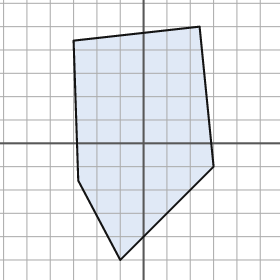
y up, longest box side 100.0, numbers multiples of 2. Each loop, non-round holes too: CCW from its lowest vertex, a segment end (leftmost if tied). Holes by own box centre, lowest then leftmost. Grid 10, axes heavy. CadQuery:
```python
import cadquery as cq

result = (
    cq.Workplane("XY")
    .moveTo(-10.0, -50.0)
    .lineTo(30.0, -10.0)
    .lineTo(24.0, 50.0)
    .lineTo(-30.0, 44.0)
    .lineTo(-28.0, -16.0)
    .close()
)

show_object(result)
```